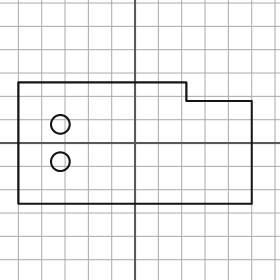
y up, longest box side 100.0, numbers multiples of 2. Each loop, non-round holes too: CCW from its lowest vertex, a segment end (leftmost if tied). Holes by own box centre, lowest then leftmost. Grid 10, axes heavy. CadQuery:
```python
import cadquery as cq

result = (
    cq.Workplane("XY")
    .moveTo(-50.0, -26.0)
    .lineTo(50.0, -26.0)
    .lineTo(50.0, 18.0)
    .lineTo(22.0, 18.0)
    .lineTo(22.0, 26.0)
    .lineTo(-50.0, 26.0)
    .close()
    .moveTo(-32.0, -8.0)
    .circle(4.0)
    .moveTo(-32.0, 8.0)
    .circle(4.0)
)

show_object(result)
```